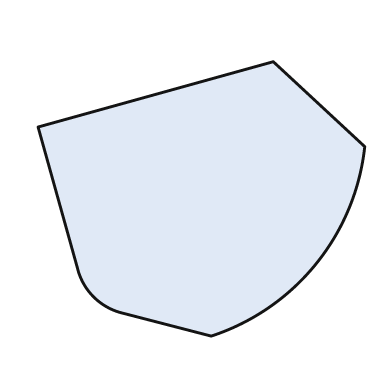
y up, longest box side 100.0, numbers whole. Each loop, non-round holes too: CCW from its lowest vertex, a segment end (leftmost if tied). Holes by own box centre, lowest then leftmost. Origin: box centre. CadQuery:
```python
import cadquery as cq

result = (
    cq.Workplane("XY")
    .moveTo(3.0, -42.0)
    .threePointArc((35.0, -20.0), (50.0, 16.0))
    .lineTo(22.0, 42.0)
    .lineTo(-50.0, 22.0)
    .lineTo(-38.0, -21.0)
    .threePointArc((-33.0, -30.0), (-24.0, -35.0))
    .close()
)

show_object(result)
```